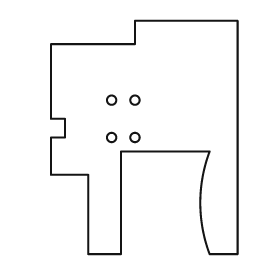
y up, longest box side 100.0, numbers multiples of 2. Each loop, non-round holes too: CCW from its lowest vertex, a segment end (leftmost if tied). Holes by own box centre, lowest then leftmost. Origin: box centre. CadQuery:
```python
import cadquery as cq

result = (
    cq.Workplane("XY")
    .moveTo(-24.0, -50.0)
    .lineTo(-10.0, -50.0)
    .lineTo(-10.0, -6.0)
    .lineTo(28.0, -6.0)
    .threePointArc((24.0, -28.0), (28.0, -50.0))
    .lineTo(40.0, -50.0)
    .lineTo(40.0, 50.0)
    .lineTo(-4.0, 50.0)
    .lineTo(-4.0, 40.0)
    .lineTo(-40.0, 40.0)
    .lineTo(-40.0, 8.0)
    .lineTo(-34.0, 8.0)
    .lineTo(-34.0, 0.0)
    .lineTo(-40.0, 0.0)
    .lineTo(-40.0, -16.0)
    .lineTo(-24.0, -16.0)
    .close()
    .moveTo(-14.0, 0.0)
    .circle(2.0)
    .moveTo(-4.0, 0.0)
    .circle(2.0)
    .moveTo(-14.0, 16.0)
    .circle(2.0)
    .moveTo(-4.0, 16.0)
    .circle(2.0)
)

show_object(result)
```